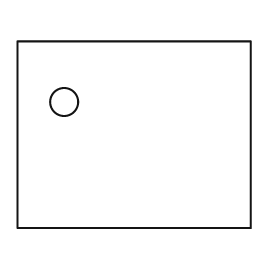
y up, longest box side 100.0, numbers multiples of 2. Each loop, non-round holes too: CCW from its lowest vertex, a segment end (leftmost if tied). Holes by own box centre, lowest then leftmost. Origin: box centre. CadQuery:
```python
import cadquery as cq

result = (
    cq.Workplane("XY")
    .moveTo(-50.0, -40.0)
    .lineTo(50.0, -40.0)
    .lineTo(50.0, 40.0)
    .lineTo(-50.0, 40.0)
    .close()
    .moveTo(-30.0, 14.0)
    .circle(6.0)
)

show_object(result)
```